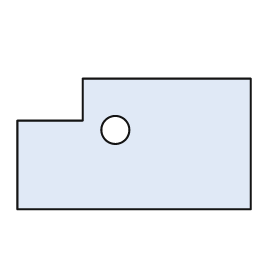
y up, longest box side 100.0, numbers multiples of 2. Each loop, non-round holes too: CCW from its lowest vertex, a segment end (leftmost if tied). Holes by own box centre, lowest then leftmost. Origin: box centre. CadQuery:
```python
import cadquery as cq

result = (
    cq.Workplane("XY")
    .moveTo(-50.0, -28.0)
    .lineTo(50.0, -28.0)
    .lineTo(50.0, 28.0)
    .lineTo(-22.0, 28.0)
    .lineTo(-22.0, 10.0)
    .lineTo(-50.0, 10.0)
    .close()
    .moveTo(-8.0, 6.0)
    .circle(6.0)
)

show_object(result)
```